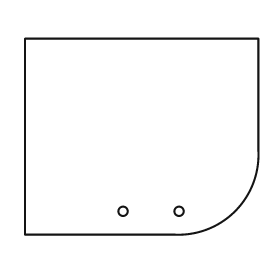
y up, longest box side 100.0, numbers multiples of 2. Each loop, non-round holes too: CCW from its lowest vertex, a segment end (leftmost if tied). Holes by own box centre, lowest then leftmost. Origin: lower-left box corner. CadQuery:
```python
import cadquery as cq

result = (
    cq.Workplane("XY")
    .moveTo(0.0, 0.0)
    .lineTo(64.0, 0.0)
    .threePointArc((90.0, 10.0), (100.0, 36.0))
    .lineTo(100.0, 84.0)
    .lineTo(0.0, 84.0)
    .close()
    .moveTo(42.0, 10.0)
    .circle(2.0)
    .moveTo(66.0, 10.0)
    .circle(2.0)
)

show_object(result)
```